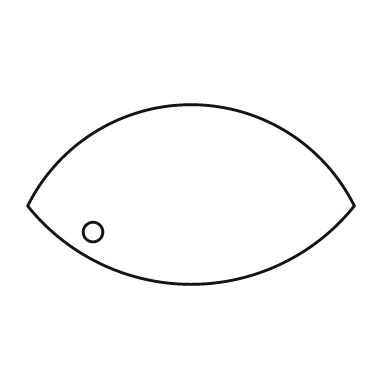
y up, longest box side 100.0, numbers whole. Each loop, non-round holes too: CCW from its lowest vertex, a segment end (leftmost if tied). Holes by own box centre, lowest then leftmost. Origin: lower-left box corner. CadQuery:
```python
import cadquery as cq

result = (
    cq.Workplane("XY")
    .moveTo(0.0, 24.0)
    .threePointArc((50.0, 0.0), (100.0, 24.0))
    .threePointArc((50.0, 55.0), (0.0, 24.0))
    .close()
    .moveTo(20.0, 16.0)
    .circle(3.0)
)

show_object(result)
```